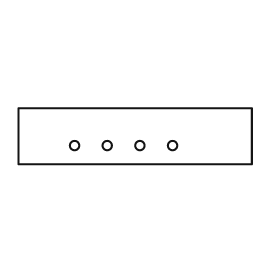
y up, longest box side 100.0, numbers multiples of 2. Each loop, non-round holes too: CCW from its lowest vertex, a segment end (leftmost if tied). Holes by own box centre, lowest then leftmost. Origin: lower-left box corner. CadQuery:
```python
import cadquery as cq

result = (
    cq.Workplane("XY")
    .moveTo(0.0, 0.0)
    .lineTo(100.0, 0.0)
    .lineTo(100.0, 24.0)
    .lineTo(0.0, 24.0)
    .close()
    .moveTo(24.0, 8.0)
    .circle(2.0)
    .moveTo(38.0, 8.0)
    .circle(2.0)
    .moveTo(52.0, 8.0)
    .circle(2.0)
    .moveTo(66.0, 8.0)
    .circle(2.0)
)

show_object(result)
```